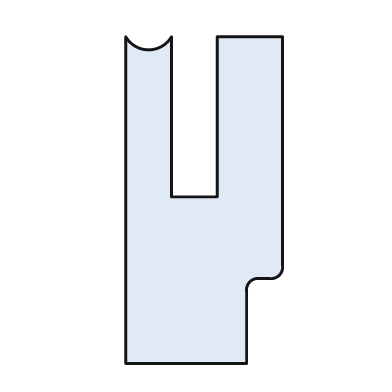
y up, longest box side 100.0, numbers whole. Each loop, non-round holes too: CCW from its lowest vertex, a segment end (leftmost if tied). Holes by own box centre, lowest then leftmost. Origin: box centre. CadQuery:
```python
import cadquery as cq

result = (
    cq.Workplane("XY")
    .moveTo(-24.0, -50.0)
    .lineTo(13.0, -50.0)
    .lineTo(13.0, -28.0)
    .threePointArc((14.0, -25.0), (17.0, -24.0))
    .lineTo(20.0, -24.0)
    .threePointArc((23.0, -23.0), (24.0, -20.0))
    .lineTo(24.0, 50.0)
    .lineTo(4.0, 50.0)
    .lineTo(4.0, 1.0)
    .lineTo(-10.0, 1.0)
    .lineTo(-10.0, 50.0)
    .threePointArc((-17.0, 46.0), (-24.0, 50.0))
    .close()
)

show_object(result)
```